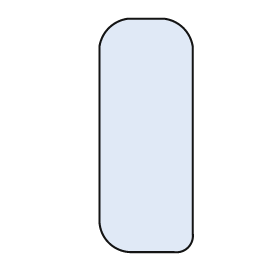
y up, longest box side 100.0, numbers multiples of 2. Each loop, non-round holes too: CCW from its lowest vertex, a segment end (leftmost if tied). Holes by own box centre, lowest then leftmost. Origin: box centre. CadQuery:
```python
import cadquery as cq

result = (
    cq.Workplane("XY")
    .moveTo(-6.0, -50.0)
    .lineTo(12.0, -50.0)
    .threePointArc((18.0, -48.0), (20.0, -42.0))
    .lineTo(20.0, 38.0)
    .threePointArc((16.0, 46.0), (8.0, 50.0))
    .lineTo(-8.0, 50.0)
    .threePointArc((-16.0, 46.0), (-20.0, 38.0))
    .lineTo(-20.0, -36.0)
    .threePointArc((-16.0, -46.0), (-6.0, -50.0))
    .close()
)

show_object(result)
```